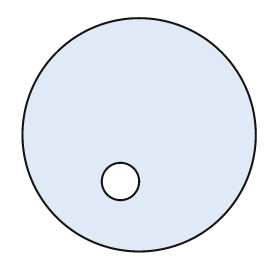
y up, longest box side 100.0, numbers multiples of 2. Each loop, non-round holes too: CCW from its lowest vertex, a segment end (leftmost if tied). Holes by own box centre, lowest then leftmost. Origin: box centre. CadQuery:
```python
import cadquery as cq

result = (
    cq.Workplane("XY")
    .moveTo(0.0, 0.0)
    .circle(50.0)
    .moveTo(-8.0, -20.0)
    .circle(8.0)
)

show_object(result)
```